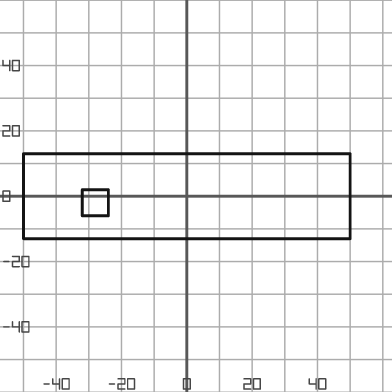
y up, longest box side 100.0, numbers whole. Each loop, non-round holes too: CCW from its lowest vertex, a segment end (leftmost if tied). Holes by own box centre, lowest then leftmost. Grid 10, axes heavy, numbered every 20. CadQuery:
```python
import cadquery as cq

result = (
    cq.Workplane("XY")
    .moveTo(-50.0, -13.0)
    .lineTo(50.0, -13.0)
    .lineTo(50.0, 13.0)
    .lineTo(-50.0, 13.0)
    .close()
    .moveTo(-32.0, -6.0)
    .lineTo(-24.0, -6.0)
    .lineTo(-24.0, 2.0)
    .lineTo(-32.0, 2.0)
    .close()
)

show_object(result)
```